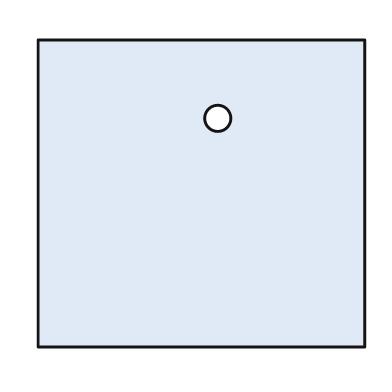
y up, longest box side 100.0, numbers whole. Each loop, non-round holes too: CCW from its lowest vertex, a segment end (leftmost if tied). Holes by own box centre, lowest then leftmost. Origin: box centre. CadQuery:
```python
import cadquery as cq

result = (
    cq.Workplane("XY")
    .moveTo(-50.0, -47.0)
    .lineTo(50.0, -47.0)
    .lineTo(50.0, 47.0)
    .lineTo(-50.0, 47.0)
    .close()
    .moveTo(5.0, 23.0)
    .circle(4.0)
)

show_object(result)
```